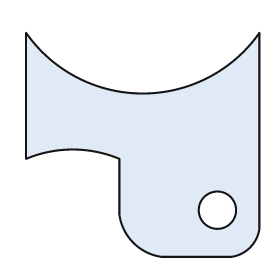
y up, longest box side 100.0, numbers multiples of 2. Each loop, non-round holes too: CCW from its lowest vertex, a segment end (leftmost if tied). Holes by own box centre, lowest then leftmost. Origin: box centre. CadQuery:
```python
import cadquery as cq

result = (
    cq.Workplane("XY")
    .moveTo(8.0, -48.0)
    .lineTo(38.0, -48.0)
    .threePointArc((46.0, -44.0), (50.0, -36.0))
    .lineTo(50.0, 48.0)
    .threePointArc((0.0, 22.0), (-50.0, 48.0))
    .lineTo(-50.0, -6.0)
    .threePointArc((-30.0, -2.0), (-10.0, -6.0))
    .lineTo(-10.0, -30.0)
    .threePointArc((-4.0, -42.0), (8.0, -48.0))
    .close()
    .moveTo(32.0, -28.0)
    .circle(8.0)
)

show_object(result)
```